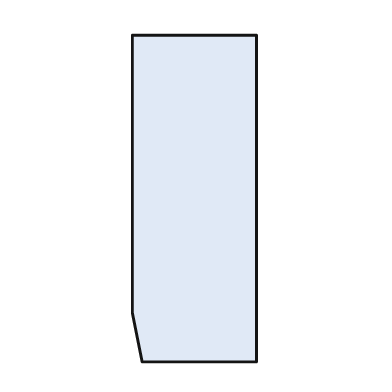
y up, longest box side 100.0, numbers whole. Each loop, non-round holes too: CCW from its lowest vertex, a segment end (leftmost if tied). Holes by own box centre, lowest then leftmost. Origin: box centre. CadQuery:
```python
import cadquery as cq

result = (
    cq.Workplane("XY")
    .moveTo(-16.0, -50.0)
    .lineTo(19.0, -50.0)
    .lineTo(19.0, 50.0)
    .lineTo(-19.0, 50.0)
    .lineTo(-19.0, -35.0)
    .close()
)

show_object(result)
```